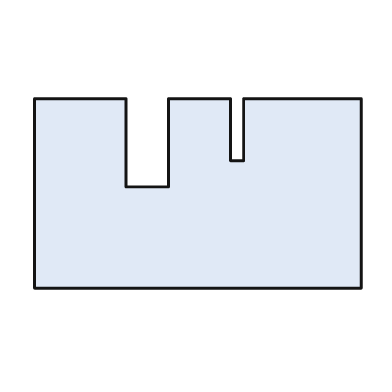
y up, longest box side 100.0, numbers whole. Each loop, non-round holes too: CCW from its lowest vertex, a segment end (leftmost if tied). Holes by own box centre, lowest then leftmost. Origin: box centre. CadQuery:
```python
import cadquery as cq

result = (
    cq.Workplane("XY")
    .moveTo(-50.0, -29.0)
    .lineTo(50.0, -29.0)
    .lineTo(50.0, 29.0)
    .lineTo(14.0, 29.0)
    .lineTo(14.0, 10.0)
    .lineTo(10.0, 10.0)
    .lineTo(10.0, 29.0)
    .lineTo(-9.0, 29.0)
    .lineTo(-9.0, 2.0)
    .lineTo(-22.0, 2.0)
    .lineTo(-22.0, 29.0)
    .lineTo(-50.0, 29.0)
    .close()
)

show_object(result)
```